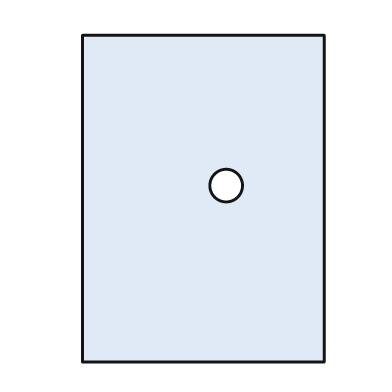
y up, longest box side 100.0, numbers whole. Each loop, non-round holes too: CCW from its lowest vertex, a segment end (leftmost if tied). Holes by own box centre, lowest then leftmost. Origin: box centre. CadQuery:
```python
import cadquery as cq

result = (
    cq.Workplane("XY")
    .moveTo(-37.0, -50.0)
    .lineTo(37.0, -50.0)
    .lineTo(37.0, 50.0)
    .lineTo(-37.0, 50.0)
    .close()
    .moveTo(7.0, 4.0)
    .circle(5.0)
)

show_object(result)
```